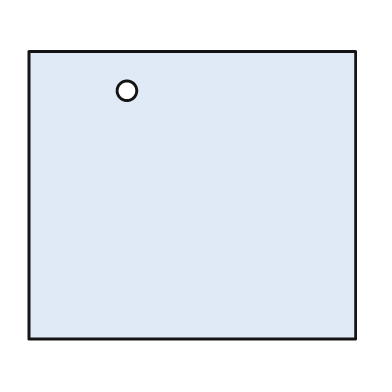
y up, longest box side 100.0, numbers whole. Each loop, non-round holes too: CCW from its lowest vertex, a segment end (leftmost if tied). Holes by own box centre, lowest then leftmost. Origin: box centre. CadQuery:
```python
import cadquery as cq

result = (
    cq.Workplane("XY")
    .moveTo(-50.0, -44.0)
    .lineTo(50.0, -44.0)
    .lineTo(50.0, 44.0)
    .lineTo(-50.0, 44.0)
    .close()
    .moveTo(-20.0, 32.0)
    .circle(3.0)
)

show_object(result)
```